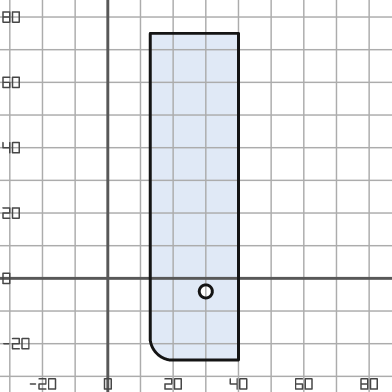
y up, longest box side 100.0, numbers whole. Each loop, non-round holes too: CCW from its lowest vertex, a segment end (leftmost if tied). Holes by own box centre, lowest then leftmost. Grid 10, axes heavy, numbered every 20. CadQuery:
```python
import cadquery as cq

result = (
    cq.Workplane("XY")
    .moveTo(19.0, -25.0)
    .lineTo(40.0, -25.0)
    .lineTo(40.0, 75.0)
    .lineTo(13.0, 75.0)
    .lineTo(13.0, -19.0)
    .threePointArc((15.0, -23.0), (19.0, -25.0))
    .close()
    .moveTo(30.0, -4.0)
    .circle(2.0)
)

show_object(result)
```